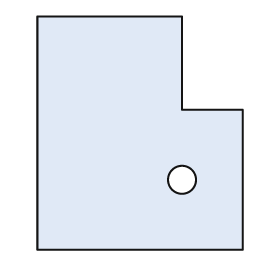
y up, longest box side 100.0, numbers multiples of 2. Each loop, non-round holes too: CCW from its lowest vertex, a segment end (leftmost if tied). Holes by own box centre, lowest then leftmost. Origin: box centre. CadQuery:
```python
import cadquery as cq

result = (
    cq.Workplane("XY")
    .moveTo(-44.0, -50.0)
    .lineTo(44.0, -50.0)
    .lineTo(44.0, 10.0)
    .lineTo(18.0, 10.0)
    .lineTo(18.0, 50.0)
    .lineTo(-44.0, 50.0)
    .close()
    .moveTo(18.0, -20.0)
    .circle(6.0)
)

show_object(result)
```